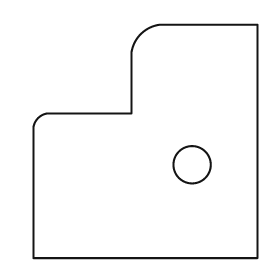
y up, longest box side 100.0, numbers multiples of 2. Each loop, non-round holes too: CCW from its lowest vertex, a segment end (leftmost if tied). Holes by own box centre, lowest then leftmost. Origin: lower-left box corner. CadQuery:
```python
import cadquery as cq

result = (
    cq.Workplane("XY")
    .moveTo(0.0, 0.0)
    .lineTo(96.0, 0.0)
    .lineTo(96.0, 100.0)
    .lineTo(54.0, 100.0)
    .threePointArc((46.0, 96.0), (42.0, 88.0))
    .lineTo(42.0, 62.0)
    .lineTo(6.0, 62.0)
    .threePointArc((2.0, 60.0), (0.0, 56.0))
    .close()
    .moveTo(68.0, 40.0)
    .circle(8.0)
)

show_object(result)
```